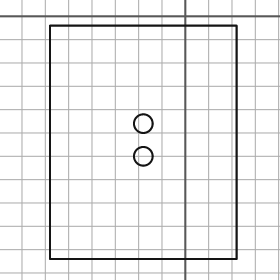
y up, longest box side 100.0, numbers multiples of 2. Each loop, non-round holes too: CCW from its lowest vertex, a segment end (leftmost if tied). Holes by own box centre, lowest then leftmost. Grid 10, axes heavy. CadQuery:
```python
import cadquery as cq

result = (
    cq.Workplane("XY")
    .moveTo(-58.0, -104.0)
    .lineTo(22.0, -104.0)
    .lineTo(22.0, -4.0)
    .lineTo(-58.0, -4.0)
    .close()
    .moveTo(-18.0, -60.0)
    .circle(4.0)
    .moveTo(-18.0, -46.0)
    .circle(4.0)
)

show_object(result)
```